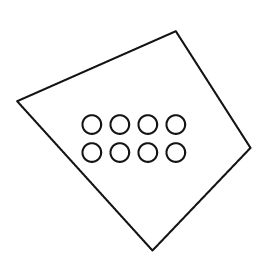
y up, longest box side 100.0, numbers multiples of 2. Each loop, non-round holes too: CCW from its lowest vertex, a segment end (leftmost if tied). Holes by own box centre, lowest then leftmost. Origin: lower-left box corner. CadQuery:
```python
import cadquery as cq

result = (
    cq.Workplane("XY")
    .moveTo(58.0, 0.0)
    .lineTo(100.0, 44.0)
    .lineTo(68.0, 94.0)
    .lineTo(0.0, 64.0)
    .close()
    .moveTo(32.0, 42.0)
    .circle(4.0)
    .moveTo(44.0, 42.0)
    .circle(4.0)
    .moveTo(56.0, 42.0)
    .circle(4.0)
    .moveTo(68.0, 42.0)
    .circle(4.0)
    .moveTo(32.0, 54.0)
    .circle(4.0)
    .moveTo(44.0, 54.0)
    .circle(4.0)
    .moveTo(56.0, 54.0)
    .circle(4.0)
    .moveTo(68.0, 54.0)
    .circle(4.0)
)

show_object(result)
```